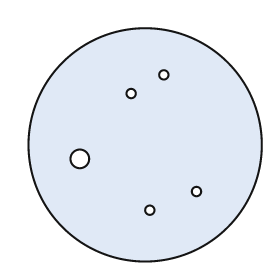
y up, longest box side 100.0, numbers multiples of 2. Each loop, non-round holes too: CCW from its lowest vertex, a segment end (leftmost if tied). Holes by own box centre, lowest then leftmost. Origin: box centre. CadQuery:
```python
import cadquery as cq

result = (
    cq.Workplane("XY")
    .moveTo(0.0, 0.0)
    .circle(50.0)
    .moveTo(2.0, -28.0)
    .circle(2.0)
    .moveTo(22.0, -20.0)
    .circle(2.0)
    .moveTo(-28.0, -6.0)
    .circle(4.0)
    .moveTo(-6.0, 22.0)
    .circle(2.0)
    .moveTo(8.0, 30.0)
    .circle(2.0)
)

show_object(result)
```